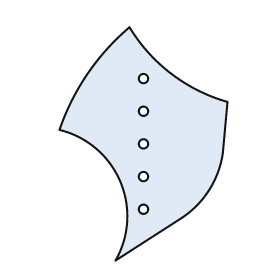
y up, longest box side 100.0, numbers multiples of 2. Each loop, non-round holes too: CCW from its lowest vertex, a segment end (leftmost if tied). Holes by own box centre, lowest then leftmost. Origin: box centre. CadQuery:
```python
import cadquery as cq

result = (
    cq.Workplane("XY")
    .moveTo(-12.0, -50.0)
    .lineTo(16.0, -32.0)
    .threePointArc((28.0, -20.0), (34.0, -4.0))
    .lineTo(36.0, 18.0)
    .threePointArc((12.0, 30.0), (-6.0, 50.0))
    .threePointArc((-24.0, 30.0), (-36.0, 6.0))
    .threePointArc((-10.0, -16.0), (-12.0, -50.0))
    .close()
    .moveTo(0.0, -28.0)
    .circle(2.0)
    .moveTo(0.0, -14.0)
    .circle(2.0)
    .moveTo(0.0, 0.0)
    .circle(2.0)
    .moveTo(0.0, 14.0)
    .circle(2.0)
    .moveTo(0.0, 28.0)
    .circle(2.0)
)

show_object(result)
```